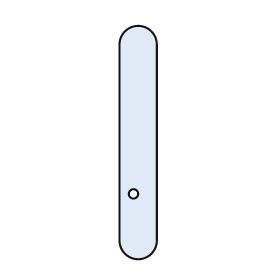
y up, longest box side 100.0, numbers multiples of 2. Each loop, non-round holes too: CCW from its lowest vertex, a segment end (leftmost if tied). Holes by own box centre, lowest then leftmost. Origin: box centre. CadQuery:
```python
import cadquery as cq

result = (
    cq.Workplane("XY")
    .moveTo(-8.0, -42.0)
    .threePointArc((0.0, -50.0), (8.0, -42.0))
    .lineTo(8.0, 42.0)
    .threePointArc((0.0, 50.0), (-8.0, 42.0))
    .close()
    .moveTo(-2.0, -22.0)
    .circle(2.0)
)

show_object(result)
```